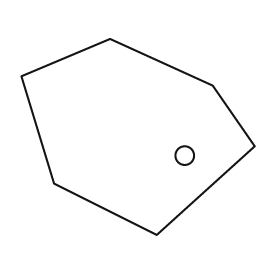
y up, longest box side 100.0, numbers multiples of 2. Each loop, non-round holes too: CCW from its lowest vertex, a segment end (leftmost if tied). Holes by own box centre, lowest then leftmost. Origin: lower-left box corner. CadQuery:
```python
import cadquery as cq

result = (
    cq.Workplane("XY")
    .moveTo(58.0, 0.0)
    .lineTo(100.0, 38.0)
    .lineTo(82.0, 64.0)
    .lineTo(38.0, 84.0)
    .lineTo(0.0, 68.0)
    .lineTo(14.0, 22.0)
    .close()
    .moveTo(70.0, 34.0)
    .circle(4.0)
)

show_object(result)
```